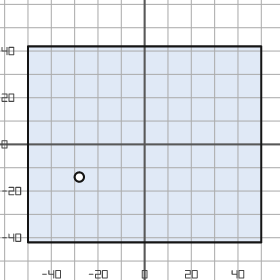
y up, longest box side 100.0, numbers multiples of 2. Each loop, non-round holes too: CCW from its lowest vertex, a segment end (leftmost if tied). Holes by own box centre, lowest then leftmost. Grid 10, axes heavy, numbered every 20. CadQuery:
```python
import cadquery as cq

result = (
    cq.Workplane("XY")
    .moveTo(-50.0, -42.0)
    .lineTo(50.0, -42.0)
    .lineTo(50.0, 42.0)
    .lineTo(-50.0, 42.0)
    .close()
    .moveTo(-28.0, -14.0)
    .circle(2.0)
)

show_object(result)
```